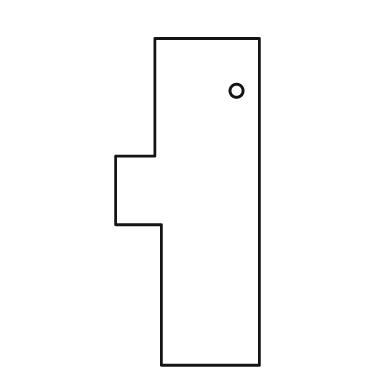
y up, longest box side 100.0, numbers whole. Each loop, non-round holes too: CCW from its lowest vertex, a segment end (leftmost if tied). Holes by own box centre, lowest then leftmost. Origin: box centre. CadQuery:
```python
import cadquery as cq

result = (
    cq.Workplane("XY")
    .moveTo(-8.0, -50.0)
    .lineTo(22.0, -50.0)
    .lineTo(22.0, 50.0)
    .lineTo(-10.0, 50.0)
    .lineTo(-10.0, 14.0)
    .lineTo(-22.0, 14.0)
    .lineTo(-22.0, -7.0)
    .lineTo(-8.0, -7.0)
    .close()
    .moveTo(15.0, 34.0)
    .circle(2.0)
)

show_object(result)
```